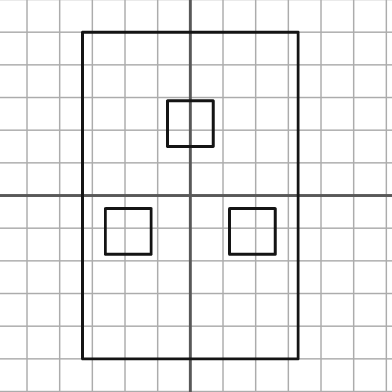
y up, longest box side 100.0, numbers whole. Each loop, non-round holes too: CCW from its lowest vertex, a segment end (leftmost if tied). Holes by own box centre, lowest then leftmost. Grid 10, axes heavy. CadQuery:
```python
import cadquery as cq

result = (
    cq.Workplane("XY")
    .moveTo(-33.0, -50.0)
    .lineTo(33.0, -50.0)
    .lineTo(33.0, 50.0)
    .lineTo(-33.0, 50.0)
    .close()
    .moveTo(-26.0, -18.0)
    .lineTo(-12.0, -18.0)
    .lineTo(-12.0, -4.0)
    .lineTo(-26.0, -4.0)
    .close()
    .moveTo(12.0, -18.0)
    .lineTo(26.0, -18.0)
    .lineTo(26.0, -4.0)
    .lineTo(12.0, -4.0)
    .close()
    .moveTo(-7.0, 15.0)
    .lineTo(7.0, 15.0)
    .lineTo(7.0, 29.0)
    .lineTo(-7.0, 29.0)
    .close()
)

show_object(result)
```